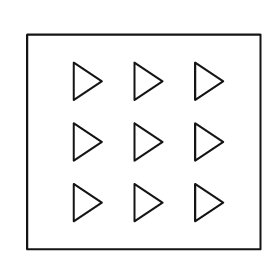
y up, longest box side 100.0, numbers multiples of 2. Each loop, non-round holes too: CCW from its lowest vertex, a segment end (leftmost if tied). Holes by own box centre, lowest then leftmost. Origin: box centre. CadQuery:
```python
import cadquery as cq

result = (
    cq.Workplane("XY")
    .moveTo(-50.0, -46.0)
    .lineTo(50.0, -46.0)
    .lineTo(50.0, 46.0)
    .lineTo(-50.0, 46.0)
    .close()
    .moveTo(-30.0, -34.0)
    .lineTo(-18.0, -26.0)
    .lineTo(-30.0, -18.0)
    .close()
    .moveTo(-4.0, -34.0)
    .lineTo(8.0, -26.0)
    .lineTo(-4.0, -18.0)
    .close()
    .moveTo(22.0, -34.0)
    .lineTo(34.0, -26.0)
    .lineTo(22.0, -18.0)
    .close()
    .moveTo(-30.0, -8.0)
    .lineTo(-18.0, 0.0)
    .lineTo(-30.0, 8.0)
    .close()
    .moveTo(-4.0, -8.0)
    .lineTo(8.0, 0.0)
    .lineTo(-4.0, 8.0)
    .close()
    .moveTo(22.0, -8.0)
    .lineTo(34.0, 0.0)
    .lineTo(22.0, 8.0)
    .close()
    .moveTo(-30.0, 18.0)
    .lineTo(-18.0, 26.0)
    .lineTo(-30.0, 34.0)
    .close()
    .moveTo(-4.0, 18.0)
    .lineTo(8.0, 26.0)
    .lineTo(-4.0, 34.0)
    .close()
    .moveTo(22.0, 18.0)
    .lineTo(34.0, 26.0)
    .lineTo(22.0, 34.0)
    .close()
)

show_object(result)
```